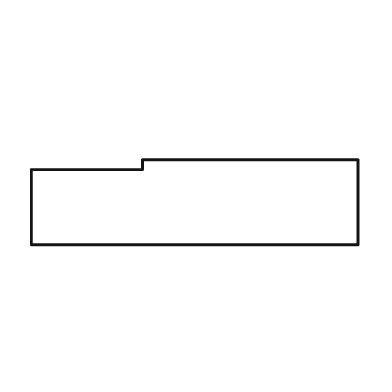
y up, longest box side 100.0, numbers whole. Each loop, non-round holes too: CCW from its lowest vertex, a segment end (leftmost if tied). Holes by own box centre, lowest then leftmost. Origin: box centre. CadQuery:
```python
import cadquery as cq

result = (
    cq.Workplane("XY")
    .moveTo(-50.0, -13.0)
    .lineTo(50.0, -13.0)
    .lineTo(50.0, 13.0)
    .lineTo(-16.0, 13.0)
    .lineTo(-16.0, 10.0)
    .lineTo(-50.0, 10.0)
    .close()
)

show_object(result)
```